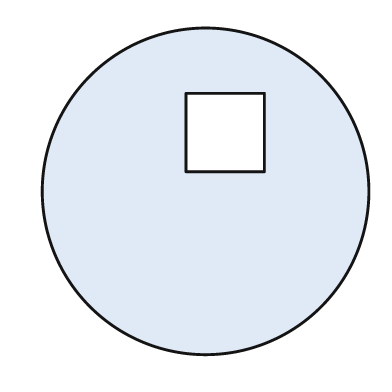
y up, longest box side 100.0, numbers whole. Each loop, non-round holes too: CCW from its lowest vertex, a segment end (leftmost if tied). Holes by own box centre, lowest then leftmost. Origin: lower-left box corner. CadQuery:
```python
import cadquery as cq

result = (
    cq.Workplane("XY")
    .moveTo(50.0, 50.0)
    .circle(50.0)
    .moveTo(44.0, 56.0)
    .lineTo(68.0, 56.0)
    .lineTo(68.0, 80.0)
    .lineTo(44.0, 80.0)
    .close()
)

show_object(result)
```